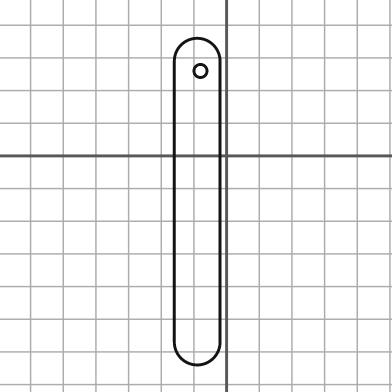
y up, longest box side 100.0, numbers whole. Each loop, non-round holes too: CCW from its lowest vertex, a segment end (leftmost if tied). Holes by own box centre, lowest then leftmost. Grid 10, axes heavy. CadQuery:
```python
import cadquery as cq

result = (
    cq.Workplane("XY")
    .moveTo(-16.0, -57.0)
    .threePointArc((-9.0, -64.0), (-2.0, -57.0))
    .lineTo(-2.0, 29.0)
    .threePointArc((-9.0, 36.0), (-16.0, 29.0))
    .close()
    .moveTo(-8.0, 26.0)
    .circle(2.0)
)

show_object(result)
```